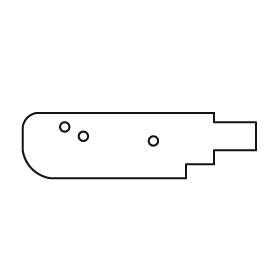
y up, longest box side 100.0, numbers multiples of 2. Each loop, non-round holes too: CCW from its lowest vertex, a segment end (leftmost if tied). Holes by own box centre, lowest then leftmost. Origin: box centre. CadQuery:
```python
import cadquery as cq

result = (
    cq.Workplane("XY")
    .moveTo(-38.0, -14.0)
    .lineTo(20.0, -14.0)
    .lineTo(20.0, -8.0)
    .lineTo(32.0, -8.0)
    .lineTo(32.0, -2.0)
    .lineTo(50.0, -2.0)
    .lineTo(50.0, 10.0)
    .lineTo(32.0, 10.0)
    .lineTo(32.0, 14.0)
    .lineTo(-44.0, 14.0)
    .threePointArc((-48.0, 12.0), (-50.0, 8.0))
    .lineTo(-50.0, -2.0)
    .threePointArc((-46.0, -10.0), (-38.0, -14.0))
    .close()
    .moveTo(6.0, 2.0)
    .circle(2.0)
    .moveTo(-24.0, 4.0)
    .circle(2.0)
    .moveTo(-32.0, 8.0)
    .circle(2.0)
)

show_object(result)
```